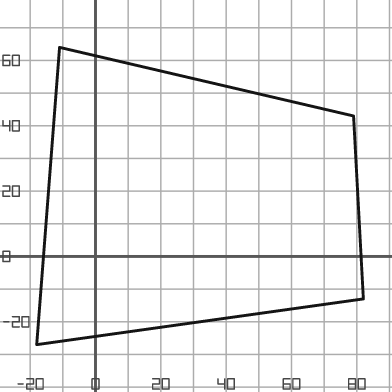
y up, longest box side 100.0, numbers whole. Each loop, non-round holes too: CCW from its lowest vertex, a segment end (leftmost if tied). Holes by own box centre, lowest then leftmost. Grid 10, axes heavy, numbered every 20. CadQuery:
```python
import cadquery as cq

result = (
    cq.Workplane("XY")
    .moveTo(-18.0, -27.0)
    .lineTo(82.0, -13.0)
    .lineTo(79.0, 43.0)
    .lineTo(-11.0, 64.0)
    .close()
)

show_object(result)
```